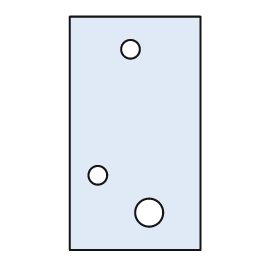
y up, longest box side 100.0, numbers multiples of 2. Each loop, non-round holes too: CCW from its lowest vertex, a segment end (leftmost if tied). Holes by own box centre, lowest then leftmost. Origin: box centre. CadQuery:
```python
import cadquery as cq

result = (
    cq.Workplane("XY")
    .moveTo(-28.0, -50.0)
    .lineTo(28.0, -50.0)
    .lineTo(28.0, 50.0)
    .lineTo(-28.0, 50.0)
    .close()
    .moveTo(6.0, -34.0)
    .circle(6.0)
    .moveTo(-16.0, -18.0)
    .circle(4.0)
    .moveTo(-2.0, 36.0)
    .circle(4.0)
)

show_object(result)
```